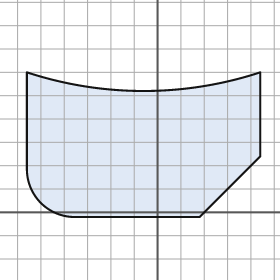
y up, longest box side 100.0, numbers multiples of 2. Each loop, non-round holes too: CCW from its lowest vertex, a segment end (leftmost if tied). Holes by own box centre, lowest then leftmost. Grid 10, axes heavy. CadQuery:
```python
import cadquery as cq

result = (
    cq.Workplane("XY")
    .moveTo(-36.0, -2.0)
    .lineTo(18.0, -2.0)
    .lineTo(44.0, 24.0)
    .lineTo(44.0, 60.0)
    .threePointArc((-6.0, 52.0), (-56.0, 60.0))
    .lineTo(-56.0, 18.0)
    .threePointArc((-50.0, 4.0), (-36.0, -2.0))
    .close()
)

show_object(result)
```